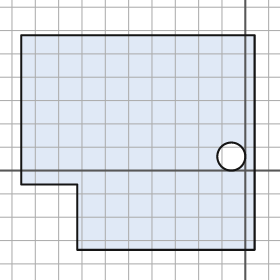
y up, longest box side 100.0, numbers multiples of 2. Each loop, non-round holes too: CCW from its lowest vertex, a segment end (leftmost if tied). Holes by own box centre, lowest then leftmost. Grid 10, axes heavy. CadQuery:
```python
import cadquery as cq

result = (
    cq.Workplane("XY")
    .moveTo(-72.0, -34.0)
    .lineTo(4.0, -34.0)
    .lineTo(4.0, 58.0)
    .lineTo(-96.0, 58.0)
    .lineTo(-96.0, -6.0)
    .lineTo(-72.0, -6.0)
    .close()
    .moveTo(-6.0, 6.0)
    .circle(6.0)
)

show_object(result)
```